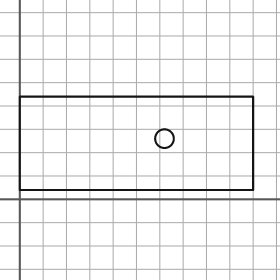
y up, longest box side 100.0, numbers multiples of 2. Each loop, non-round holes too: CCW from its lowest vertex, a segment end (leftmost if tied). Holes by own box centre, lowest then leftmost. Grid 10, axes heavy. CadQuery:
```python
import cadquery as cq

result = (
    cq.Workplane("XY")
    .moveTo(0.0, 4.0)
    .lineTo(100.0, 4.0)
    .lineTo(100.0, 44.0)
    .lineTo(0.0, 44.0)
    .close()
    .moveTo(62.0, 26.0)
    .circle(4.0)
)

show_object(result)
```